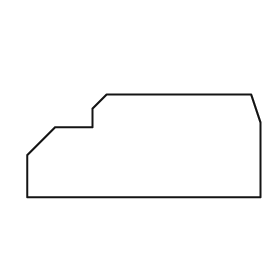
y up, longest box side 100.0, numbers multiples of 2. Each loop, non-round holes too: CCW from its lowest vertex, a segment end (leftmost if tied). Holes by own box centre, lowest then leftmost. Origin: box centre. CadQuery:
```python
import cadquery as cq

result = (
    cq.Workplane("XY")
    .moveTo(-50.0, -22.0)
    .lineTo(50.0, -22.0)
    .lineTo(50.0, 10.0)
    .lineTo(46.0, 22.0)
    .lineTo(-16.0, 22.0)
    .lineTo(-22.0, 16.0)
    .lineTo(-22.0, 8.0)
    .lineTo(-38.0, 8.0)
    .lineTo(-50.0, -4.0)
    .close()
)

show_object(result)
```